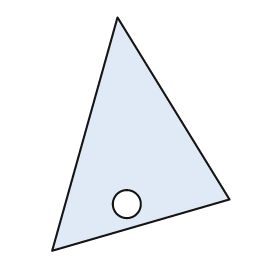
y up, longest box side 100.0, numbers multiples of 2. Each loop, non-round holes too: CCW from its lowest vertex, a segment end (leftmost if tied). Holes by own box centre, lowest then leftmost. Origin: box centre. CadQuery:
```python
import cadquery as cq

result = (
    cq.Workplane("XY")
    .moveTo(-38.0, -50.0)
    .lineTo(38.0, -28.0)
    .lineTo(-10.0, 50.0)
    .close()
    .moveTo(-6.0, -30.0)
    .circle(6.0)
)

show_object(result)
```